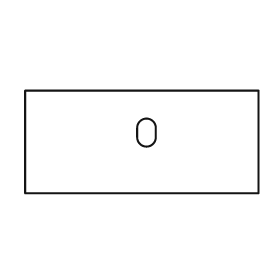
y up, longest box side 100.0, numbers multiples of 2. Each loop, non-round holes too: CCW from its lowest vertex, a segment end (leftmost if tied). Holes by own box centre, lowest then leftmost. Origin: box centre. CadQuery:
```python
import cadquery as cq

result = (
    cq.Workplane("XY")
    .moveTo(-50.0, -22.0)
    .lineTo(50.0, -22.0)
    .lineTo(50.0, 22.0)
    .lineTo(-50.0, 22.0)
    .close()
    .moveTo(-2.0, 2.0)
    .threePointArc((2.0, -2.0), (6.0, 2.0))
    .lineTo(6.0, 6.0)
    .threePointArc((2.0, 10.0), (-2.0, 6.0))
    .close()
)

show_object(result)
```